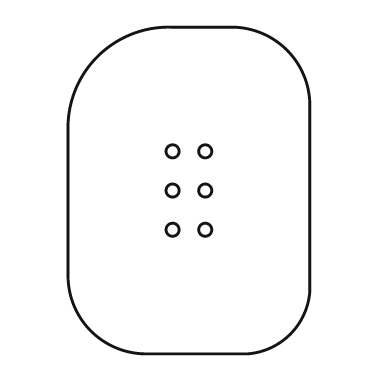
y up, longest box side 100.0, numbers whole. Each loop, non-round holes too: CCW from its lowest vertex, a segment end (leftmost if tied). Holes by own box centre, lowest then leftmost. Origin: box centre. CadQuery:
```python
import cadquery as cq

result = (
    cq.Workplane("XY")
    .moveTo(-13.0, -50.0)
    .lineTo(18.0, -50.0)
    .threePointArc((31.0, -44.0), (37.0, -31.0))
    .lineTo(37.0, 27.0)
    .threePointArc((30.0, 43.0), (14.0, 50.0))
    .lineTo(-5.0, 50.0)
    .threePointArc((-28.0, 41.0), (-37.0, 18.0))
    .lineTo(-37.0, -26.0)
    .threePointArc((-30.0, -43.0), (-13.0, -50.0))
    .close()
    .moveTo(-5.0, -12.0)
    .circle(2.0)
    .moveTo(5.0, -12.0)
    .circle(2.0)
    .moveTo(-5.0, 0.0)
    .circle(2.0)
    .moveTo(5.0, 0.0)
    .circle(2.0)
    .moveTo(-5.0, 12.0)
    .circle(2.0)
    .moveTo(5.0, 12.0)
    .circle(2.0)
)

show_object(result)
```